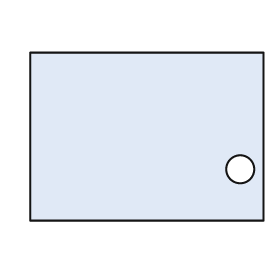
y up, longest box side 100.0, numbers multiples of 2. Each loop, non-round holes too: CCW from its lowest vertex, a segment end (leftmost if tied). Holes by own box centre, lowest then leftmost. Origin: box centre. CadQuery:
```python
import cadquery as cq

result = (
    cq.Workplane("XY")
    .moveTo(-50.0, -36.0)
    .lineTo(50.0, -36.0)
    .lineTo(50.0, 36.0)
    .lineTo(-50.0, 36.0)
    .close()
    .moveTo(40.0, -14.0)
    .circle(6.0)
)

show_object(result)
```